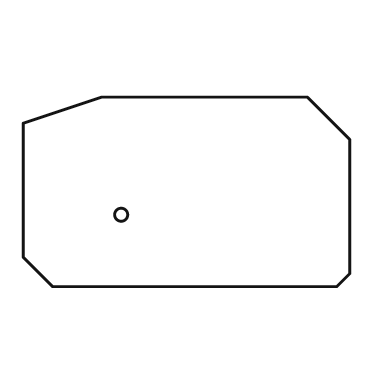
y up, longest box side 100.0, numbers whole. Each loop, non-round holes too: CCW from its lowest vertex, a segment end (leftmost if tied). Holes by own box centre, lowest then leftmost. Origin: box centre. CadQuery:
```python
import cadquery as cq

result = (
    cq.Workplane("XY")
    .moveTo(-41.0, -29.0)
    .lineTo(46.0, -29.0)
    .lineTo(50.0, -25.0)
    .lineTo(50.0, 16.0)
    .lineTo(37.0, 29.0)
    .lineTo(-26.0, 29.0)
    .lineTo(-50.0, 21.0)
    .lineTo(-50.0, -20.0)
    .close()
    .moveTo(-20.0, -7.0)
    .circle(2.0)
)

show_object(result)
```